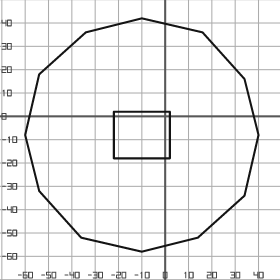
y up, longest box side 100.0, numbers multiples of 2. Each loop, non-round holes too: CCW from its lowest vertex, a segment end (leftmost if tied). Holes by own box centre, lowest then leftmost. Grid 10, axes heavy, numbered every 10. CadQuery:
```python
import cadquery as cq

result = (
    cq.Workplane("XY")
    .moveTo(-10.0, -58.0)
    .lineTo(14.0, -52.0)
    .lineTo(34.0, -34.0)
    .lineTo(40.0, -8.0)
    .lineTo(34.0, 16.0)
    .lineTo(16.0, 36.0)
    .lineTo(-10.0, 42.0)
    .lineTo(-34.0, 36.0)
    .lineTo(-54.0, 18.0)
    .lineTo(-60.0, -8.0)
    .lineTo(-54.0, -32.0)
    .lineTo(-36.0, -52.0)
    .close()
    .moveTo(-22.0, -18.0)
    .lineTo(2.0, -18.0)
    .lineTo(2.0, 2.0)
    .lineTo(-22.0, 2.0)
    .close()
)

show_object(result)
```